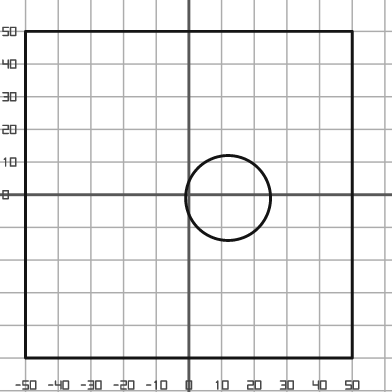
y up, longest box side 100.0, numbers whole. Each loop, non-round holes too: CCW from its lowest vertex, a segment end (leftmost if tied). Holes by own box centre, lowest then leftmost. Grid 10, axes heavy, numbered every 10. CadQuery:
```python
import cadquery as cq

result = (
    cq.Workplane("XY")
    .moveTo(-50.0, -50.0)
    .lineTo(50.0, -50.0)
    .lineTo(50.0, 50.0)
    .lineTo(-50.0, 50.0)
    .close()
    .moveTo(12.0, -1.0)
    .circle(13.0)
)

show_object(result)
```